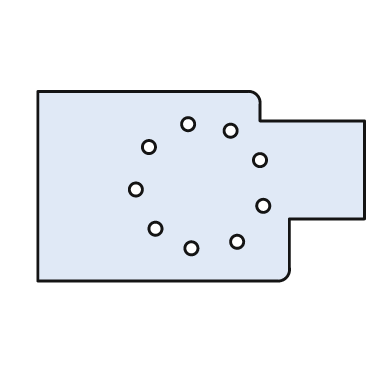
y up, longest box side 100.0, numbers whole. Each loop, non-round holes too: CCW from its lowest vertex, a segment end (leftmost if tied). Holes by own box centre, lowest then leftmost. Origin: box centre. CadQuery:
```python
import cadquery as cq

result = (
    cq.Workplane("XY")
    .moveTo(-50.0, -29.0)
    .lineTo(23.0, -29.0)
    .threePointArc((26.0, -28.0), (27.0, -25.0))
    .lineTo(27.0, -10.0)
    .lineTo(50.0, -10.0)
    .lineTo(50.0, 20.0)
    .lineTo(18.0, 20.0)
    .lineTo(18.0, 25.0)
    .threePointArc((17.0, 28.0), (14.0, 29.0))
    .lineTo(-50.0, 29.0)
    .close()
    .moveTo(-3.0, -19.0)
    .circle(2.0)
    .moveTo(11.0, -17.0)
    .circle(2.0)
    .moveTo(-14.0, -13.0)
    .circle(2.0)
    .moveTo(19.0, -6.0)
    .circle(2.0)
    .moveTo(-20.0, -1.0)
    .circle(2.0)
    .moveTo(18.0, 8.0)
    .circle(2.0)
    .moveTo(-16.0, 12.0)
    .circle(2.0)
    .moveTo(9.0, 17.0)
    .circle(2.0)
    .moveTo(-4.0, 19.0)
    .circle(2.0)
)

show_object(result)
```